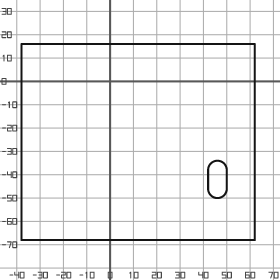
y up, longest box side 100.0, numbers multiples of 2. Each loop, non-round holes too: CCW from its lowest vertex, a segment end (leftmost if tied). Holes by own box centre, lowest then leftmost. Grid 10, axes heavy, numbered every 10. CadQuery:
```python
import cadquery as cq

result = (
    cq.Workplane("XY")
    .moveTo(-38.0, -68.0)
    .lineTo(62.0, -68.0)
    .lineTo(62.0, 16.0)
    .lineTo(-38.0, 16.0)
    .close()
    .moveTo(42.0, -46.0)
    .threePointArc((46.0, -50.0), (50.0, -46.0))
    .lineTo(50.0, -38.0)
    .threePointArc((46.0, -34.0), (42.0, -38.0))
    .close()
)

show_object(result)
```